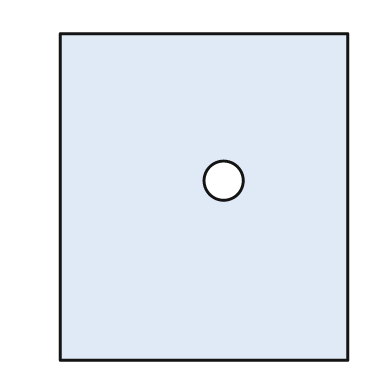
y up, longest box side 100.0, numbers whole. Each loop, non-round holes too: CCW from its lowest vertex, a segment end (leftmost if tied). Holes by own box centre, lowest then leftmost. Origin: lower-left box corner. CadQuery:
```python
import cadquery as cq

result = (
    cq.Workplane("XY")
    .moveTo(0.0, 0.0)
    .lineTo(88.0, 0.0)
    .lineTo(88.0, 100.0)
    .lineTo(0.0, 100.0)
    .close()
    .moveTo(50.0, 55.0)
    .circle(6.0)
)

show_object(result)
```